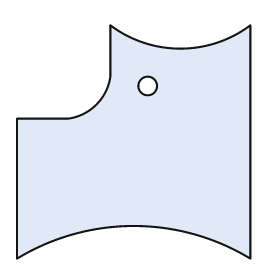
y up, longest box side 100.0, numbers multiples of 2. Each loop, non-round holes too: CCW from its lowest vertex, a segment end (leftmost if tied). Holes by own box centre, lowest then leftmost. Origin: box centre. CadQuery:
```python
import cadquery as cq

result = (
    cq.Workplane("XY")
    .moveTo(-50.0, -50.0)
    .threePointArc((0.0, -36.0), (50.0, -50.0))
    .lineTo(50.0, 50.0)
    .threePointArc((20.0, 40.0), (-10.0, 50.0))
    .lineTo(-10.0, 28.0)
    .threePointArc((-16.0, 16.0), (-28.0, 10.0))
    .lineTo(-50.0, 10.0)
    .close()
    .moveTo(6.0, 24.0)
    .circle(4.0)
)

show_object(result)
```